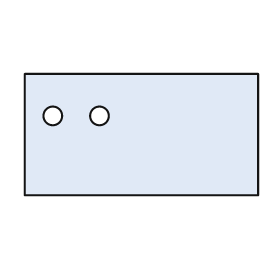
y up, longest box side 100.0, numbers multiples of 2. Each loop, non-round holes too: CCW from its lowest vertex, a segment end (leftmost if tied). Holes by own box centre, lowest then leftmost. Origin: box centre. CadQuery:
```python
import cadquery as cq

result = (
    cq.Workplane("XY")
    .moveTo(-50.0, -26.0)
    .lineTo(50.0, -26.0)
    .lineTo(50.0, 26.0)
    .lineTo(-50.0, 26.0)
    .close()
    .moveTo(-38.0, 8.0)
    .circle(4.0)
    .moveTo(-18.0, 8.0)
    .circle(4.0)
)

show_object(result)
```